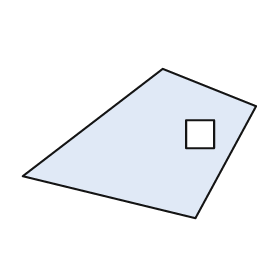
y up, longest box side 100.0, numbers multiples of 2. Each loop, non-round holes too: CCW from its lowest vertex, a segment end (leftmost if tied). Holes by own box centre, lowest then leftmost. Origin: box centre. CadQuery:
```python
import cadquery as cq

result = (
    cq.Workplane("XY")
    .moveTo(24.0, -32.0)
    .lineTo(50.0, 16.0)
    .lineTo(10.0, 32.0)
    .lineTo(-50.0, -14.0)
    .close()
    .moveTo(20.0, -2.0)
    .lineTo(32.0, -2.0)
    .lineTo(32.0, 10.0)
    .lineTo(20.0, 10.0)
    .close()
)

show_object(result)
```